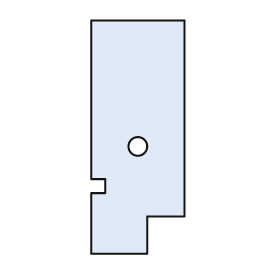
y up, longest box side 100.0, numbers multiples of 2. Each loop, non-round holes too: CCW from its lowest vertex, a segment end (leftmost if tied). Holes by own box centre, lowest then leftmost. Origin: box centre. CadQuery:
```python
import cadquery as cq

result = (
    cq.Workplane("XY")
    .moveTo(-20.0, -50.0)
    .lineTo(4.0, -50.0)
    .lineTo(4.0, -34.0)
    .lineTo(20.0, -34.0)
    .lineTo(20.0, 50.0)
    .lineTo(-20.0, 50.0)
    .lineTo(-20.0, -18.0)
    .lineTo(-14.0, -18.0)
    .lineTo(-14.0, -24.0)
    .lineTo(-20.0, -24.0)
    .close()
    .moveTo(0.0, -4.0)
    .circle(4.0)
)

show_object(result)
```